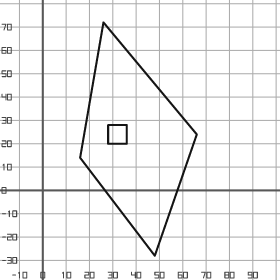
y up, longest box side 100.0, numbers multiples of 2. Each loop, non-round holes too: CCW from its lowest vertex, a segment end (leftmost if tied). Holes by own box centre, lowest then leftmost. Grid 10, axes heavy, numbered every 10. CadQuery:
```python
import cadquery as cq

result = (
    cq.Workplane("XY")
    .moveTo(48.0, -28.0)
    .lineTo(66.0, 24.0)
    .lineTo(26.0, 72.0)
    .lineTo(16.0, 14.0)
    .close()
    .moveTo(28.0, 20.0)
    .lineTo(36.0, 20.0)
    .lineTo(36.0, 28.0)
    .lineTo(28.0, 28.0)
    .close()
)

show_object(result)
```